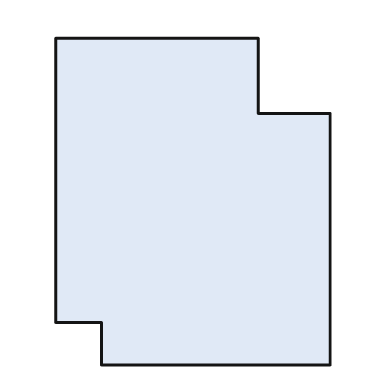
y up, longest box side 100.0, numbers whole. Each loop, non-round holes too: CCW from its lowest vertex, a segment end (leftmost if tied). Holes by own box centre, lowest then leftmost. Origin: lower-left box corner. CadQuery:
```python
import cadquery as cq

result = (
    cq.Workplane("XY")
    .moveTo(14.0, 0.0)
    .lineTo(84.0, 0.0)
    .lineTo(84.0, 77.0)
    .lineTo(62.0, 77.0)
    .lineTo(62.0, 100.0)
    .lineTo(0.0, 100.0)
    .lineTo(0.0, 13.0)
    .lineTo(14.0, 13.0)
    .close()
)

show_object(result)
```